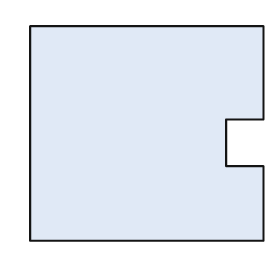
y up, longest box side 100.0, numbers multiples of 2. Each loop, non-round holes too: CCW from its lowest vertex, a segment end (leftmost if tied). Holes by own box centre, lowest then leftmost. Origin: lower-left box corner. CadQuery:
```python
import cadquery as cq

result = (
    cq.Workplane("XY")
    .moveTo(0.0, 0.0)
    .lineTo(100.0, 0.0)
    .lineTo(100.0, 32.0)
    .lineTo(84.0, 32.0)
    .lineTo(84.0, 52.0)
    .lineTo(100.0, 52.0)
    .lineTo(100.0, 92.0)
    .lineTo(0.0, 92.0)
    .close()
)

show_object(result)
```